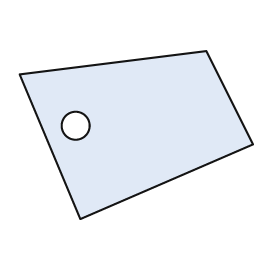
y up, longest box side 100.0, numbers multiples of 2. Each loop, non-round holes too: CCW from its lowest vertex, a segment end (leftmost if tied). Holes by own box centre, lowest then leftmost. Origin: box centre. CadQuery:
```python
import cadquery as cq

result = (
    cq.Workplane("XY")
    .moveTo(-24.0, -36.0)
    .lineTo(50.0, -4.0)
    .lineTo(30.0, 36.0)
    .lineTo(-50.0, 26.0)
    .close()
    .moveTo(-26.0, 4.0)
    .circle(6.0)
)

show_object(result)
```